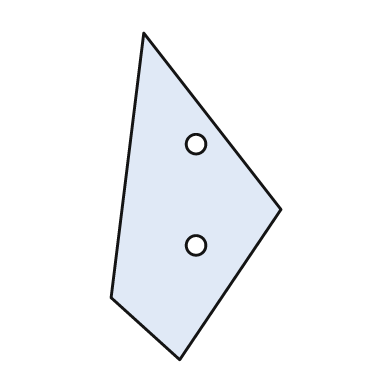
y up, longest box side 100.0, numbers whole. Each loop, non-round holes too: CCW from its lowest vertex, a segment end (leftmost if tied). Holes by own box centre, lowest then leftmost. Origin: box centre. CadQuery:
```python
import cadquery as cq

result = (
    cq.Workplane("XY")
    .moveTo(-5.0, -50.0)
    .lineTo(26.0, -4.0)
    .lineTo(-16.0, 50.0)
    .lineTo(-26.0, -31.0)
    .close()
    .moveTo(0.0, -15.0)
    .circle(3.0)
    .moveTo(0.0, 16.0)
    .circle(3.0)
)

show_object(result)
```